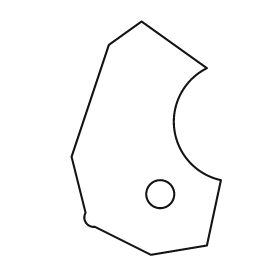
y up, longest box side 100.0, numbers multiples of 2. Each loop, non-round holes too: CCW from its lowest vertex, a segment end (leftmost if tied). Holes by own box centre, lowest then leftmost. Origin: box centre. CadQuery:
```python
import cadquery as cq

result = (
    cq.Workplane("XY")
    .moveTo(2.0, -50.0)
    .lineTo(26.0, -46.0)
    .lineTo(32.0, -18.0)
    .threePointArc((12.0, 4.0), (26.0, 30.0))
    .lineTo(-2.0, 50.0)
    .lineTo(-16.0, 40.0)
    .lineTo(-32.0, -8.0)
    .lineTo(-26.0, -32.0)
    .threePointArc((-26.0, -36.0), (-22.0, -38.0))
    .close()
    .moveTo(6.0, -24.0)
    .circle(6.0)
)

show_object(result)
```